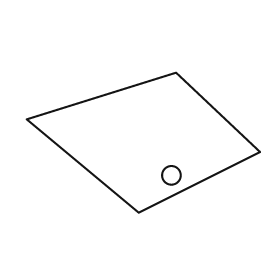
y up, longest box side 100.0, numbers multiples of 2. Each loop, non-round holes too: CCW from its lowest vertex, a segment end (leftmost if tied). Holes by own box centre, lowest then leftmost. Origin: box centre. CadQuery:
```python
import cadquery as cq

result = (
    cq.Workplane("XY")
    .moveTo(-2.0, -30.0)
    .lineTo(50.0, -4.0)
    .lineTo(14.0, 30.0)
    .lineTo(-50.0, 10.0)
    .close()
    .moveTo(12.0, -14.0)
    .circle(4.0)
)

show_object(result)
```